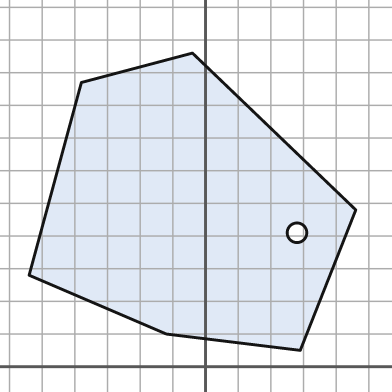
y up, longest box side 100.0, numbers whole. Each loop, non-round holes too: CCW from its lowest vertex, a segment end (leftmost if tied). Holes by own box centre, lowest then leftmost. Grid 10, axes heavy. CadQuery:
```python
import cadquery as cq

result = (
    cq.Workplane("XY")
    .moveTo(29.0, 5.0)
    .lineTo(46.0, 48.0)
    .lineTo(-4.0, 96.0)
    .lineTo(-38.0, 87.0)
    .lineTo(-54.0, 28.0)
    .lineTo(-12.0, 10.0)
    .close()
    .moveTo(28.0, 41.0)
    .circle(3.0)
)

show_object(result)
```